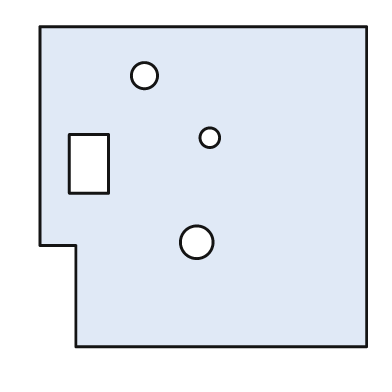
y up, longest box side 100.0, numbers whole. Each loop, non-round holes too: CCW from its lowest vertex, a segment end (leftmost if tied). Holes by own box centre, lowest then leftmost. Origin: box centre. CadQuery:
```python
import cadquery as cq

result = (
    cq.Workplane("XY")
    .moveTo(-39.0, -49.0)
    .lineTo(50.0, -49.0)
    .lineTo(50.0, 49.0)
    .lineTo(-50.0, 49.0)
    .lineTo(-50.0, -18.0)
    .lineTo(-39.0, -18.0)
    .close()
    .moveTo(-2.0, -17.0)
    .circle(5.0)
    .moveTo(-41.0, -2.0)
    .lineTo(-29.0, -2.0)
    .lineTo(-29.0, 16.0)
    .lineTo(-41.0, 16.0)
    .close()
    .moveTo(2.0, 15.0)
    .circle(3.0)
    .moveTo(-18.0, 34.0)
    .circle(4.0)
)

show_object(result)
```